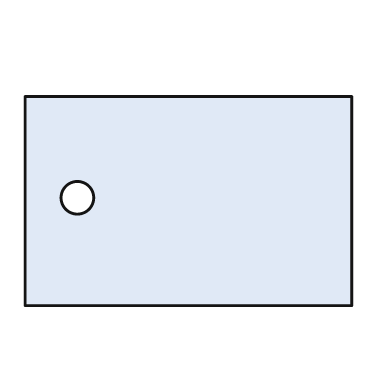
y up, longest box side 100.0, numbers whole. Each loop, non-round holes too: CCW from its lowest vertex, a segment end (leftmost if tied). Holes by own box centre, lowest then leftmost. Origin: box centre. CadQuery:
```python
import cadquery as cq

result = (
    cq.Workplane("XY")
    .moveTo(-50.0, -32.0)
    .lineTo(50.0, -32.0)
    .lineTo(50.0, 32.0)
    .lineTo(-50.0, 32.0)
    .close()
    .moveTo(-34.0, 1.0)
    .circle(5.0)
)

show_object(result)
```